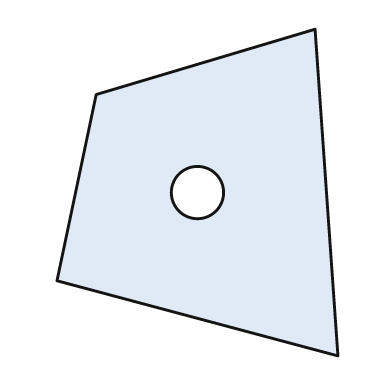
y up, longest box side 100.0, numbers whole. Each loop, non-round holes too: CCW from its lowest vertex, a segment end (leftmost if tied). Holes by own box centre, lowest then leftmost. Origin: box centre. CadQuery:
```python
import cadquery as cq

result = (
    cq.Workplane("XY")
    .moveTo(43.0, -50.0)
    .lineTo(36.0, 50.0)
    .lineTo(-31.0, 30.0)
    .lineTo(-43.0, -27.0)
    .close()
    .moveTo(0.0, 0.0)
    .circle(8.0)
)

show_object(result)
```